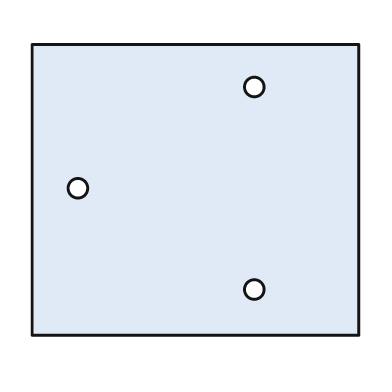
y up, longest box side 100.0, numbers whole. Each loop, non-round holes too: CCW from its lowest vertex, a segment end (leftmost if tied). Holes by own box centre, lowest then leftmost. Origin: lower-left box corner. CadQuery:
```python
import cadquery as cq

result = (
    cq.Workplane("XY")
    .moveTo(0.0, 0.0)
    .lineTo(100.0, 0.0)
    .lineTo(100.0, 89.0)
    .lineTo(0.0, 89.0)
    .close()
    .moveTo(68.0, 14.0)
    .circle(3.0)
    .moveTo(14.0, 45.0)
    .circle(3.0)
    .moveTo(68.0, 76.0)
    .circle(3.0)
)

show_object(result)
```